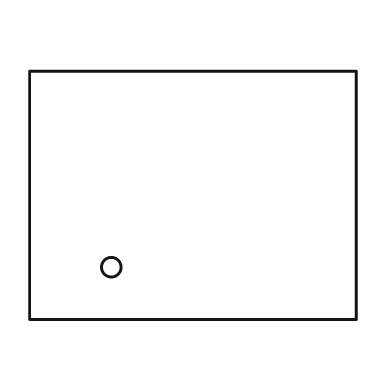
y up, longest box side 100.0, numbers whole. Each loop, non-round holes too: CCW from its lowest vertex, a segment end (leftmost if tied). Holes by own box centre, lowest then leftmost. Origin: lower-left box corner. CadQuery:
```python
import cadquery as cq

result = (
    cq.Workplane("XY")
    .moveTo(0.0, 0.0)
    .lineTo(100.0, 0.0)
    .lineTo(100.0, 76.0)
    .lineTo(0.0, 76.0)
    .close()
    .moveTo(25.0, 16.0)
    .circle(3.0)
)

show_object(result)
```